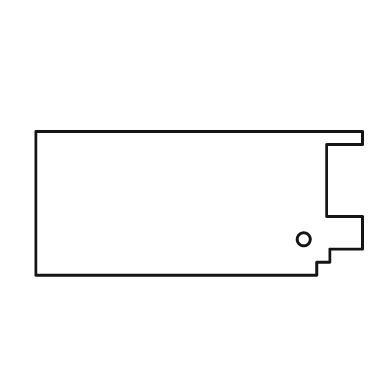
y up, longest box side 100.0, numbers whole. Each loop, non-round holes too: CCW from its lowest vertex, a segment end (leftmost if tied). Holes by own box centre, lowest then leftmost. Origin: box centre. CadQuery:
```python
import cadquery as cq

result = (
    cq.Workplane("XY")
    .moveTo(-50.0, -22.0)
    .lineTo(36.0, -22.0)
    .lineTo(36.0, -18.0)
    .lineTo(40.0, -18.0)
    .lineTo(40.0, -14.0)
    .lineTo(50.0, -14.0)
    .lineTo(50.0, -4.0)
    .lineTo(39.0, -4.0)
    .lineTo(39.0, 18.0)
    .lineTo(50.0, 18.0)
    .lineTo(50.0, 22.0)
    .lineTo(-50.0, 22.0)
    .close()
    .moveTo(32.0, -11.0)
    .circle(2.0)
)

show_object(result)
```